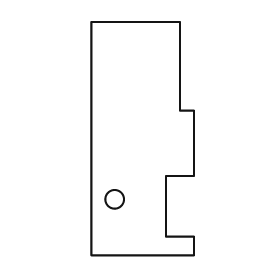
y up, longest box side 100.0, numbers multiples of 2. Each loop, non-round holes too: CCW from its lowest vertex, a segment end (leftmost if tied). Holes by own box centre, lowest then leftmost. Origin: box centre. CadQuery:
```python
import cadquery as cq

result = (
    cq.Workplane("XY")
    .moveTo(-22.0, -50.0)
    .lineTo(22.0, -50.0)
    .lineTo(22.0, -42.0)
    .lineTo(10.0, -42.0)
    .lineTo(10.0, -16.0)
    .lineTo(22.0, -16.0)
    .lineTo(22.0, 12.0)
    .lineTo(16.0, 12.0)
    .lineTo(16.0, 50.0)
    .lineTo(-22.0, 50.0)
    .close()
    .moveTo(-12.0, -26.0)
    .circle(4.0)
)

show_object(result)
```